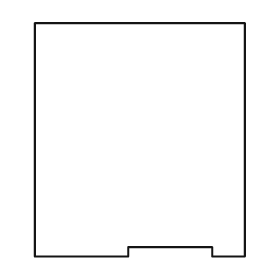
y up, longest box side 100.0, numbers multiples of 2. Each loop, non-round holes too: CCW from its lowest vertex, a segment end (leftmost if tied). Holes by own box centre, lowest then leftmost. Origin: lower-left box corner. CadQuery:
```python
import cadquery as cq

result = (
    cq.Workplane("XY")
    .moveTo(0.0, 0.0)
    .lineTo(40.0, 0.0)
    .lineTo(40.0, 4.0)
    .lineTo(76.0, 4.0)
    .lineTo(76.0, 0.0)
    .lineTo(90.0, 0.0)
    .lineTo(90.0, 100.0)
    .lineTo(0.0, 100.0)
    .close()
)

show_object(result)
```